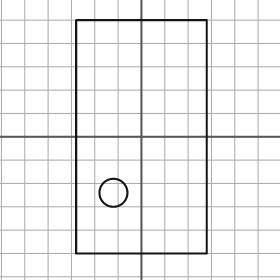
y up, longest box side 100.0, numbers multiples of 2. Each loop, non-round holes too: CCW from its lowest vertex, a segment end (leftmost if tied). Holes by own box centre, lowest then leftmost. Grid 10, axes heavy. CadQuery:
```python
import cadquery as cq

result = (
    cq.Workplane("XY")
    .moveTo(-28.0, -50.0)
    .lineTo(28.0, -50.0)
    .lineTo(28.0, 50.0)
    .lineTo(-28.0, 50.0)
    .close()
    .moveTo(-12.0, -24.0)
    .circle(6.0)
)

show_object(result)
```